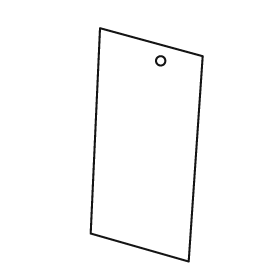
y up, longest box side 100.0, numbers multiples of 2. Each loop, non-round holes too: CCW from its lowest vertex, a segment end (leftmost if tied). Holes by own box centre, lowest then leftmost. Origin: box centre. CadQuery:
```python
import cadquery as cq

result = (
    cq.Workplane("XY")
    .moveTo(18.0, -50.0)
    .lineTo(24.0, 38.0)
    .lineTo(-20.0, 50.0)
    .lineTo(-24.0, -38.0)
    .close()
    .moveTo(6.0, 36.0)
    .circle(2.0)
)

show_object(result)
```